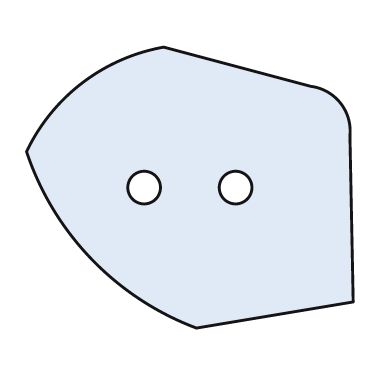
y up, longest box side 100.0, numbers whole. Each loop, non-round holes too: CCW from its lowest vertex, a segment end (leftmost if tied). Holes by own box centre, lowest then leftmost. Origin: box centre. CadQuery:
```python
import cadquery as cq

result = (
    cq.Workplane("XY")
    .moveTo(2.0, -43.0)
    .lineTo(50.0, -35.0)
    .lineTo(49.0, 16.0)
    .threePointArc((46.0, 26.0), (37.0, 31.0))
    .lineTo(-8.0, 43.0)
    .threePointArc((-33.0, 32.0), (-50.0, 11.0))
    .threePointArc((-30.0, -22.0), (2.0, -43.0))
    .close()
    .moveTo(-14.0, 0.0)
    .circle(5.0)
    .moveTo(14.0, 0.0)
    .circle(5.0)
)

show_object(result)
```